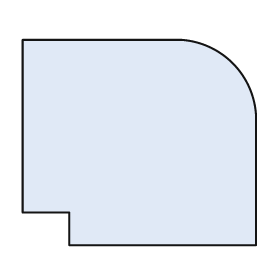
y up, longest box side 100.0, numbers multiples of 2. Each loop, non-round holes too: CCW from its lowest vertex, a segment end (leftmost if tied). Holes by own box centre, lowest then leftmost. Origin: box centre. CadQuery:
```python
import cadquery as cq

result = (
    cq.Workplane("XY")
    .moveTo(-30.0, -44.0)
    .lineTo(50.0, -44.0)
    .lineTo(50.0, 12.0)
    .threePointArc((40.0, 34.0), (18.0, 44.0))
    .lineTo(-50.0, 44.0)
    .lineTo(-50.0, -30.0)
    .lineTo(-30.0, -30.0)
    .close()
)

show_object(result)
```